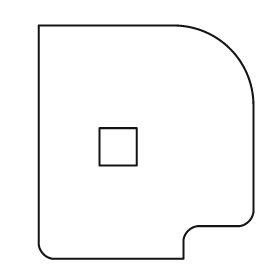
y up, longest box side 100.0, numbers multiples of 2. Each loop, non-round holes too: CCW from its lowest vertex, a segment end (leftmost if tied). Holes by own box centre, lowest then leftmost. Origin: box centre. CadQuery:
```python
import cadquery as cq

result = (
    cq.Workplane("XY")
    .moveTo(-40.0, -50.0)
    .lineTo(16.0, -50.0)
    .lineTo(16.0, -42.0)
    .threePointArc((18.0, -38.0), (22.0, -36.0))
    .lineTo(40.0, -36.0)
    .threePointArc((44.0, -34.0), (46.0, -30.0))
    .lineTo(46.0, 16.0)
    .threePointArc((36.0, 40.0), (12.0, 50.0))
    .lineTo(-46.0, 50.0)
    .lineTo(-46.0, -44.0)
    .threePointArc((-44.0, -48.0), (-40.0, -50.0))
    .close()
    .moveTo(-20.0, -10.0)
    .lineTo(-4.0, -10.0)
    .lineTo(-4.0, 6.0)
    .lineTo(-20.0, 6.0)
    .close()
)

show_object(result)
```